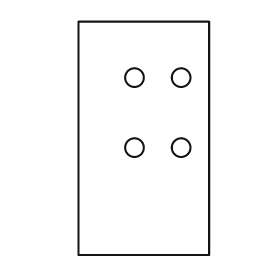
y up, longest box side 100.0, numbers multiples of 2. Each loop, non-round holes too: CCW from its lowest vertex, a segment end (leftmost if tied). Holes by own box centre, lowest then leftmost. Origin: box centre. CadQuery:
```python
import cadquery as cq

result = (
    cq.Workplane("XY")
    .moveTo(-28.0, -50.0)
    .lineTo(28.0, -50.0)
    .lineTo(28.0, 50.0)
    .lineTo(-28.0, 50.0)
    .close()
    .moveTo(-4.0, -4.0)
    .circle(4.0)
    .moveTo(16.0, -4.0)
    .circle(4.0)
    .moveTo(-4.0, 26.0)
    .circle(4.0)
    .moveTo(16.0, 26.0)
    .circle(4.0)
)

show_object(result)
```